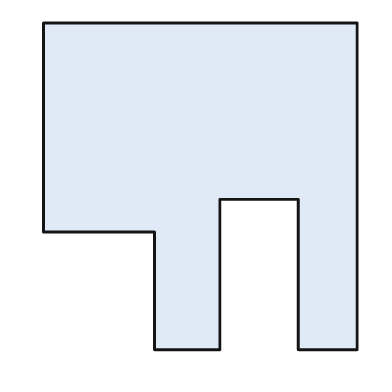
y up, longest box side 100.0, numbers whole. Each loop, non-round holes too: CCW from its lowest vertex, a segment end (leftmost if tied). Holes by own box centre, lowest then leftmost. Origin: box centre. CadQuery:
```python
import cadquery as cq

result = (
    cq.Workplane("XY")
    .moveTo(-14.0, -50.0)
    .lineTo(6.0, -50.0)
    .lineTo(6.0, -4.0)
    .lineTo(30.0, -4.0)
    .lineTo(30.0, -50.0)
    .lineTo(48.0, -50.0)
    .lineTo(48.0, 50.0)
    .lineTo(-48.0, 50.0)
    .lineTo(-48.0, -14.0)
    .lineTo(-14.0, -14.0)
    .close()
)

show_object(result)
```